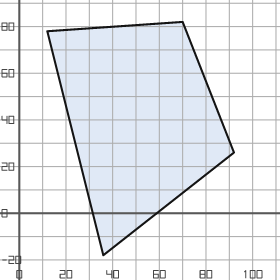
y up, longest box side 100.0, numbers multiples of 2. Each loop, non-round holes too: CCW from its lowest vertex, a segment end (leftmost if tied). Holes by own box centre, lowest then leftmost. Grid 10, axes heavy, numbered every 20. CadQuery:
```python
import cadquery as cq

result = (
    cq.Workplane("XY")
    .moveTo(36.0, -18.0)
    .lineTo(92.0, 26.0)
    .lineTo(70.0, 82.0)
    .lineTo(12.0, 78.0)
    .close()
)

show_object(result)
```